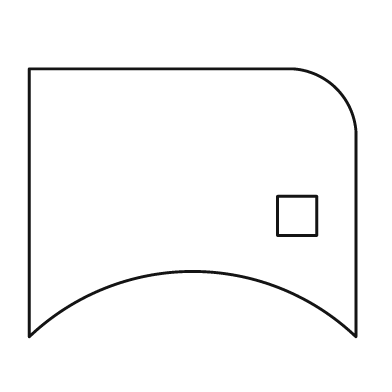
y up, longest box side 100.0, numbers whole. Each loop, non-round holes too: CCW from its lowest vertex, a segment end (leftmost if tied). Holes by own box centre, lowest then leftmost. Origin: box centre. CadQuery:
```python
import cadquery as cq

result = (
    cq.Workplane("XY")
    .moveTo(-50.0, -41.0)
    .threePointArc((0.0, -21.0), (50.0, -41.0))
    .lineTo(50.0, 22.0)
    .threePointArc((44.0, 35.0), (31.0, 41.0))
    .lineTo(-50.0, 41.0)
    .close()
    .moveTo(26.0, -10.0)
    .lineTo(38.0, -10.0)
    .lineTo(38.0, 2.0)
    .lineTo(26.0, 2.0)
    .close()
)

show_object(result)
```